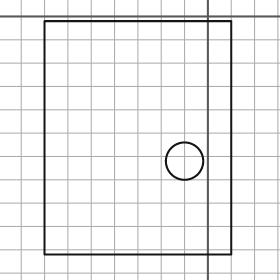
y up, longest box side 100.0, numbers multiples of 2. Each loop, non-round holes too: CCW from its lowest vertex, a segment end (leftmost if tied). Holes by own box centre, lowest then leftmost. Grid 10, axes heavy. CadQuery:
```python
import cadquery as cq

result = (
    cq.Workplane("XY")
    .moveTo(-70.0, -102.0)
    .lineTo(10.0, -102.0)
    .lineTo(10.0, -2.0)
    .lineTo(-70.0, -2.0)
    .close()
    .moveTo(-10.0, -62.0)
    .circle(8.0)
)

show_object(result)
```